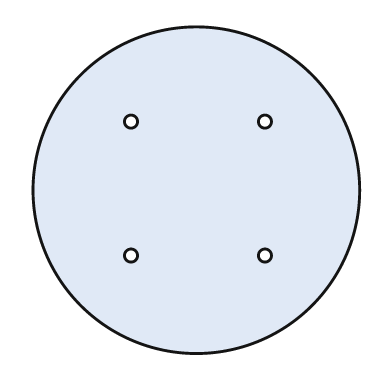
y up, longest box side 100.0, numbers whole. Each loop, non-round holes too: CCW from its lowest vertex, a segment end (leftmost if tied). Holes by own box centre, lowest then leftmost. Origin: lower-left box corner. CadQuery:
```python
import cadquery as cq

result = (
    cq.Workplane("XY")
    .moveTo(50.0, 50.0)
    .circle(50.0)
    .moveTo(30.0, 30.0)
    .circle(2.0)
    .moveTo(71.0, 30.0)
    .circle(2.0)
    .moveTo(30.0, 71.0)
    .circle(2.0)
    .moveTo(71.0, 71.0)
    .circle(2.0)
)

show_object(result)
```